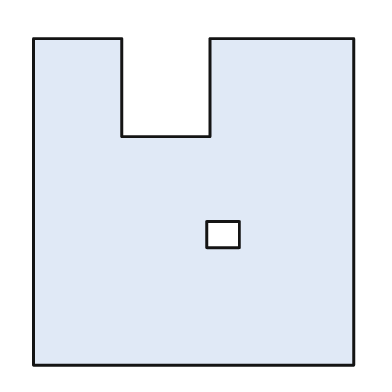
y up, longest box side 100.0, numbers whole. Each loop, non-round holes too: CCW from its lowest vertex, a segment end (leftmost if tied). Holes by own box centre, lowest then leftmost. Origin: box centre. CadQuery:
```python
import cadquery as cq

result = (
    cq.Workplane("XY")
    .moveTo(-49.0, -50.0)
    .lineTo(49.0, -50.0)
    .lineTo(49.0, 50.0)
    .lineTo(5.0, 50.0)
    .lineTo(5.0, 20.0)
    .lineTo(-22.0, 20.0)
    .lineTo(-22.0, 50.0)
    .lineTo(-49.0, 50.0)
    .close()
    .moveTo(4.0, -14.0)
    .lineTo(14.0, -14.0)
    .lineTo(14.0, -6.0)
    .lineTo(4.0, -6.0)
    .close()
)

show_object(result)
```